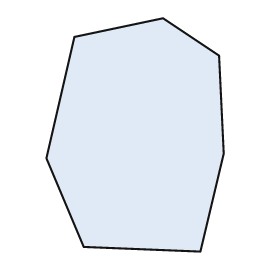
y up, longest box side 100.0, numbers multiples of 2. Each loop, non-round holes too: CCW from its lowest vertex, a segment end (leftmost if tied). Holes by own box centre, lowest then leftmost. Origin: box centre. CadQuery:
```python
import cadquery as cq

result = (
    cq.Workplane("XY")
    .moveTo(28.0, -50.0)
    .lineTo(38.0, -8.0)
    .lineTo(36.0, 34.0)
    .lineTo(12.0, 50.0)
    .lineTo(-26.0, 42.0)
    .lineTo(-38.0, -10.0)
    .lineTo(-22.0, -48.0)
    .close()
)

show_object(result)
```